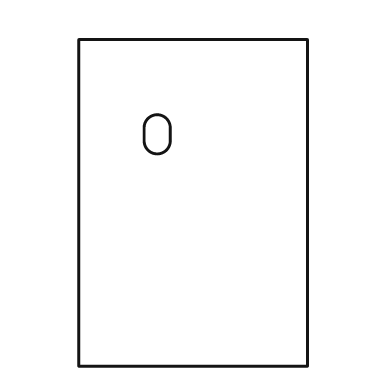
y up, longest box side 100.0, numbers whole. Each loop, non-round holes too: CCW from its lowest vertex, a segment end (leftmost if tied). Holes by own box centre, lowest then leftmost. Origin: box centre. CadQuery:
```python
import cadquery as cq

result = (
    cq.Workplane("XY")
    .moveTo(-35.0, -50.0)
    .lineTo(35.0, -50.0)
    .lineTo(35.0, 50.0)
    .lineTo(-35.0, 50.0)
    .close()
    .moveTo(-15.0, 19.0)
    .threePointArc((-11.0, 15.0), (-7.0, 19.0))
    .lineTo(-7.0, 23.0)
    .threePointArc((-11.0, 27.0), (-15.0, 23.0))
    .close()
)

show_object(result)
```